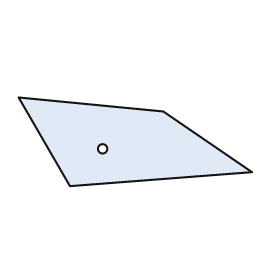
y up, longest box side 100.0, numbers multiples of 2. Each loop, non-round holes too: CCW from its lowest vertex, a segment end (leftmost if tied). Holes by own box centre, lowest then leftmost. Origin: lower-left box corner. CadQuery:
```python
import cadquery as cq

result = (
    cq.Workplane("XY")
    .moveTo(22.0, 0.0)
    .lineTo(100.0, 6.0)
    .lineTo(62.0, 32.0)
    .lineTo(0.0, 38.0)
    .close()
    .moveTo(36.0, 16.0)
    .circle(2.0)
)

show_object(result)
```